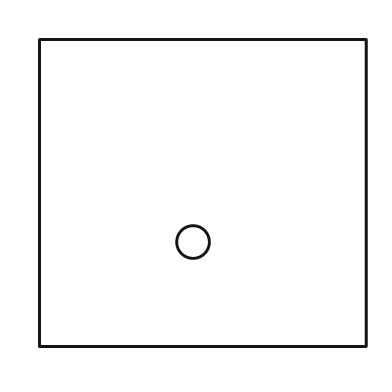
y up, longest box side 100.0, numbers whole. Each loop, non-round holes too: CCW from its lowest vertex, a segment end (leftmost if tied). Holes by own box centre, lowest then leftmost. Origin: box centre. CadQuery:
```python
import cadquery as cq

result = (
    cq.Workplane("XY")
    .moveTo(-50.0, -47.0)
    .lineTo(50.0, -47.0)
    .lineTo(50.0, 47.0)
    .lineTo(-50.0, 47.0)
    .close()
    .moveTo(-3.0, -15.0)
    .circle(5.0)
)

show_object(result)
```